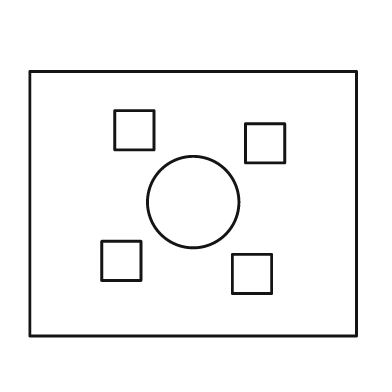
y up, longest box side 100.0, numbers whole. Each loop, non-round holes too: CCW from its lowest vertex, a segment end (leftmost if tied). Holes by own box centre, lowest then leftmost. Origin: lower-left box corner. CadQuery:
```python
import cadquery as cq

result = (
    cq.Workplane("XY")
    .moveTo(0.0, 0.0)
    .lineTo(100.0, 0.0)
    .lineTo(100.0, 81.0)
    .lineTo(0.0, 81.0)
    .close()
    .moveTo(62.0, 13.0)
    .lineTo(74.0, 13.0)
    .lineTo(74.0, 25.0)
    .lineTo(62.0, 25.0)
    .close()
    .moveTo(22.0, 17.0)
    .lineTo(34.0, 17.0)
    .lineTo(34.0, 29.0)
    .lineTo(22.0, 29.0)
    .close()
    .moveTo(50.0, 41.0)
    .circle(14.0)
    .moveTo(66.0, 53.0)
    .lineTo(78.0, 53.0)
    .lineTo(78.0, 65.0)
    .lineTo(66.0, 65.0)
    .close()
    .moveTo(26.0, 57.0)
    .lineTo(38.0, 57.0)
    .lineTo(38.0, 69.0)
    .lineTo(26.0, 69.0)
    .close()
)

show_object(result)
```